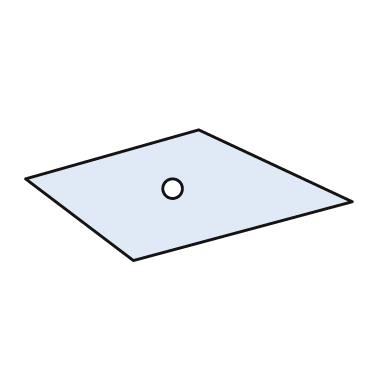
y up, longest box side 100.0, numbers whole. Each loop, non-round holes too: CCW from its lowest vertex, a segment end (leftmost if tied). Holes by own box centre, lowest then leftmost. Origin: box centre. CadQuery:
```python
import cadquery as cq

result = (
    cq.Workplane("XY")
    .moveTo(-17.0, -20.0)
    .lineTo(50.0, -2.0)
    .lineTo(3.0, 20.0)
    .lineTo(-50.0, 5.0)
    .close()
    .moveTo(-5.0, 2.0)
    .circle(3.0)
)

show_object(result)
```